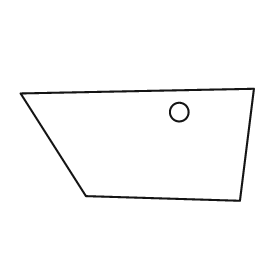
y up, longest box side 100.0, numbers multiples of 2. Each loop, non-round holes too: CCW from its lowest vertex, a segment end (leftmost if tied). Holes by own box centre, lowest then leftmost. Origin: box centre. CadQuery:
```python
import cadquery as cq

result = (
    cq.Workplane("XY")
    .moveTo(44.0, -24.0)
    .lineTo(50.0, 24.0)
    .lineTo(-50.0, 22.0)
    .lineTo(-22.0, -22.0)
    .close()
    .moveTo(18.0, 14.0)
    .circle(4.0)
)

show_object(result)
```